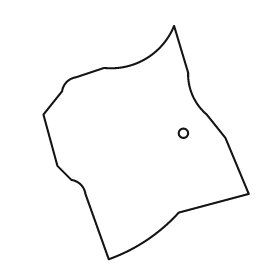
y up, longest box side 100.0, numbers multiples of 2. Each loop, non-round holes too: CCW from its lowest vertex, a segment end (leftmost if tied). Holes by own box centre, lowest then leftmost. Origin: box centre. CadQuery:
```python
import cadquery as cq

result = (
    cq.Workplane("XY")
    .moveTo(-16.0, -50.0)
    .threePointArc((0.0, -42.0), (14.0, -30.0))
    .lineTo(44.0, -22.0)
    .lineTo(34.0, 2.0)
    .lineTo(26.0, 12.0)
    .threePointArc((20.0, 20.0), (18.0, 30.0))
    .lineTo(12.0, 50.0)
    .threePointArc((0.0, 36.0), (-18.0, 32.0))
    .lineTo(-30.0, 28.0)
    .threePointArc((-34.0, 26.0), (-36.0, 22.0))
    .lineTo(-44.0, 12.0)
    .lineTo(-38.0, -10.0)
    .lineTo(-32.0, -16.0)
    .threePointArc((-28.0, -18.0), (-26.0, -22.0))
    .close()
    .moveTo(16.0, 4.0)
    .circle(2.0)
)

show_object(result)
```